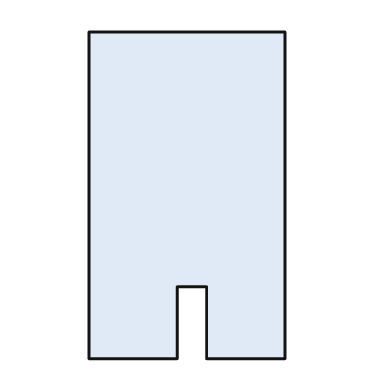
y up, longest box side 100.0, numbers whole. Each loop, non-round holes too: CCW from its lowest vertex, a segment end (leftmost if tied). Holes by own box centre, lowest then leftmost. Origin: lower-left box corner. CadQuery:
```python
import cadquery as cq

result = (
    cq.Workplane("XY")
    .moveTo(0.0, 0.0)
    .lineTo(27.0, 0.0)
    .lineTo(27.0, 22.0)
    .lineTo(36.0, 22.0)
    .lineTo(36.0, 0.0)
    .lineTo(60.0, 0.0)
    .lineTo(60.0, 100.0)
    .lineTo(0.0, 100.0)
    .close()
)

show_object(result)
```